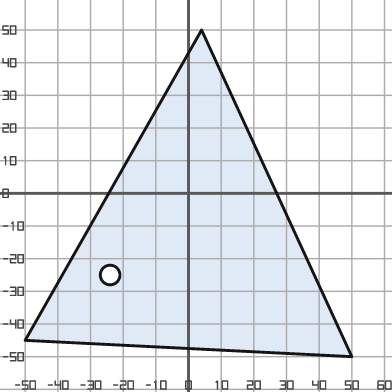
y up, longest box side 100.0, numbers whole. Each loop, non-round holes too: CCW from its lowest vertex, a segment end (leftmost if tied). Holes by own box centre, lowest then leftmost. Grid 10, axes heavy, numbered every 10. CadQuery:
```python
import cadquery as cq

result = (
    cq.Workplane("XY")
    .moveTo(50.0, -50.0)
    .lineTo(4.0, 50.0)
    .lineTo(-50.0, -45.0)
    .close()
    .moveTo(-24.0, -25.0)
    .circle(3.0)
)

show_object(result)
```